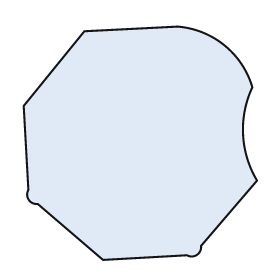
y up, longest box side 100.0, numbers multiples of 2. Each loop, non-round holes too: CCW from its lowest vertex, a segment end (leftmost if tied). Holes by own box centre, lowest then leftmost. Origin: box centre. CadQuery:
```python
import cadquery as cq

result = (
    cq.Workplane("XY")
    .moveTo(-16.0, -50.0)
    .lineTo(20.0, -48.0)
    .threePointArc((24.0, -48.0), (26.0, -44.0))
    .lineTo(50.0, -16.0)
    .threePointArc((44.0, 4.0), (48.0, 24.0))
    .threePointArc((36.0, 42.0), (16.0, 50.0))
    .lineTo(-24.0, 48.0)
    .lineTo(-50.0, 16.0)
    .lineTo(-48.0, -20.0)
    .threePointArc((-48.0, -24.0), (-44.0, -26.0))
    .close()
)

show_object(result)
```